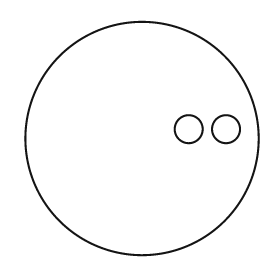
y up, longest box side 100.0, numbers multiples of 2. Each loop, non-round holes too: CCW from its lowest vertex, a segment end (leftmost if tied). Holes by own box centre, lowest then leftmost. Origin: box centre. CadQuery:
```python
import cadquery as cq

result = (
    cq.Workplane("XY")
    .moveTo(0.0, 0.0)
    .circle(50.0)
    .moveTo(20.0, 4.0)
    .circle(6.0)
    .moveTo(36.0, 4.0)
    .circle(6.0)
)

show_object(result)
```